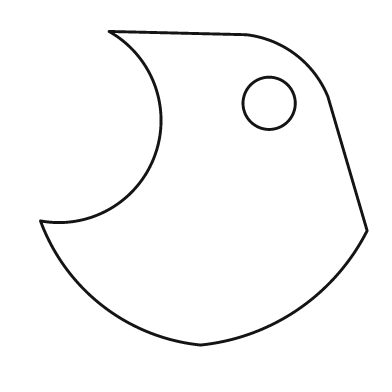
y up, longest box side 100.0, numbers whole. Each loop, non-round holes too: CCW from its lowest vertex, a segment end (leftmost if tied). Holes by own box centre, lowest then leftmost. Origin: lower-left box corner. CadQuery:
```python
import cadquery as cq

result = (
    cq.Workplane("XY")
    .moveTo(49.0, 0.0)
    .threePointArc((79.0, 11.0), (100.0, 35.0))
    .lineTo(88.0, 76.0)
    .threePointArc((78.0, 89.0), (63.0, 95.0))
    .lineTo(21.0, 96.0)
    .threePointArc((35.0, 58.0), (0.0, 38.0))
    .threePointArc((19.0, 12.0), (49.0, 0.0))
    .close()
    .moveTo(70.0, 74.0)
    .circle(8.0)
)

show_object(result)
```